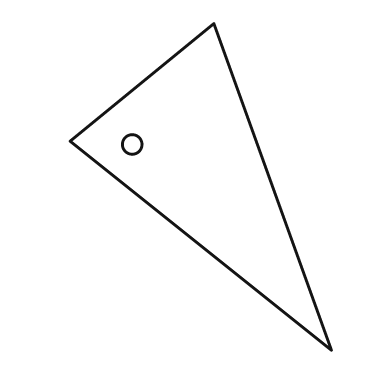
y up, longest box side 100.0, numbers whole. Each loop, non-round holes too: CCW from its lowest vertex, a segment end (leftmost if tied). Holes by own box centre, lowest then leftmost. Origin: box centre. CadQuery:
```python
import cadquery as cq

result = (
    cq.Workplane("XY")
    .moveTo(40.0, -50.0)
    .lineTo(4.0, 50.0)
    .lineTo(-40.0, 14.0)
    .close()
    .moveTo(-21.0, 13.0)
    .circle(3.0)
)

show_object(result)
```